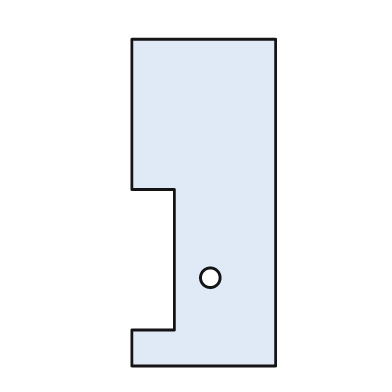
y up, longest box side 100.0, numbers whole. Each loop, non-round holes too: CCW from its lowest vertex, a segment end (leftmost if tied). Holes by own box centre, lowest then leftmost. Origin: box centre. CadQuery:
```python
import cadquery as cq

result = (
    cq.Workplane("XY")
    .moveTo(-22.0, -50.0)
    .lineTo(22.0, -50.0)
    .lineTo(22.0, 50.0)
    .lineTo(-22.0, 50.0)
    .lineTo(-22.0, 4.0)
    .lineTo(-9.0, 4.0)
    .lineTo(-9.0, -39.0)
    .lineTo(-22.0, -39.0)
    .close()
    .moveTo(2.0, -23.0)
    .circle(3.0)
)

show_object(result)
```